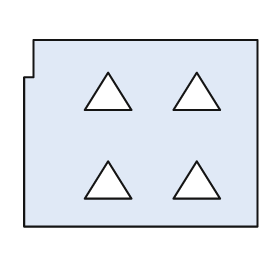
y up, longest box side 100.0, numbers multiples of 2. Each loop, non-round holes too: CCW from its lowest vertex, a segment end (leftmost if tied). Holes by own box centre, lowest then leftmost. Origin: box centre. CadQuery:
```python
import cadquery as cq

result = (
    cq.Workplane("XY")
    .moveTo(-50.0, -40.0)
    .lineTo(50.0, -40.0)
    .lineTo(50.0, 40.0)
    .lineTo(-46.0, 40.0)
    .lineTo(-46.0, 24.0)
    .lineTo(-50.0, 24.0)
    .close()
    .moveTo(-24.0, -28.0)
    .lineTo(-4.0, -28.0)
    .lineTo(-14.0, -12.0)
    .close()
    .moveTo(14.0, -28.0)
    .lineTo(34.0, -28.0)
    .lineTo(24.0, -12.0)
    .close()
    .moveTo(-24.0, 10.0)
    .lineTo(-4.0, 10.0)
    .lineTo(-14.0, 26.0)
    .close()
    .moveTo(14.0, 10.0)
    .lineTo(34.0, 10.0)
    .lineTo(24.0, 26.0)
    .close()
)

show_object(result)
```